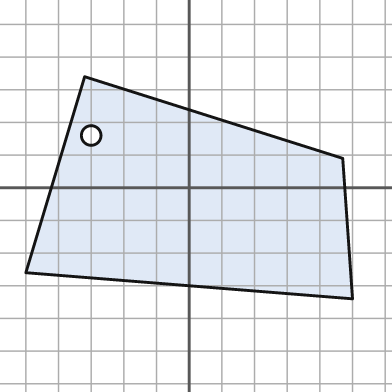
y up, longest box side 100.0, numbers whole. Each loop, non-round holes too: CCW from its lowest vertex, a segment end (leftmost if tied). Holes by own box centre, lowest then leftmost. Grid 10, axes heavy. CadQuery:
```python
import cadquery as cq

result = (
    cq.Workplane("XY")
    .moveTo(50.0, -34.0)
    .lineTo(47.0, 9.0)
    .lineTo(-32.0, 34.0)
    .lineTo(-50.0, -26.0)
    .close()
    .moveTo(-30.0, 16.0)
    .circle(3.0)
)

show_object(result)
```